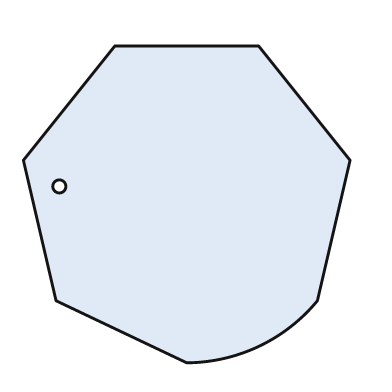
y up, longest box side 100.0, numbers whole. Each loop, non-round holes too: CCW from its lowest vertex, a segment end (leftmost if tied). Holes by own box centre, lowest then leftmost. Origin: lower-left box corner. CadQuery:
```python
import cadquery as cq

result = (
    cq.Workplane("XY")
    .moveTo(50.0, 0.0)
    .threePointArc((72.0, 5.0), (90.0, 19.0))
    .lineTo(100.0, 62.0)
    .lineTo(72.0, 97.0)
    .lineTo(28.0, 97.0)
    .lineTo(0.0, 62.0)
    .lineTo(10.0, 19.0)
    .close()
    .moveTo(11.0, 54.0)
    .circle(2.0)
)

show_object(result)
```